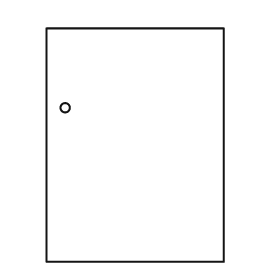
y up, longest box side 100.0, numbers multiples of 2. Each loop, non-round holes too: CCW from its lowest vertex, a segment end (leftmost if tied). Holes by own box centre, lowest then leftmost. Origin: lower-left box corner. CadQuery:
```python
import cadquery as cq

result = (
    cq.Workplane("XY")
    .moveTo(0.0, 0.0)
    .lineTo(76.0, 0.0)
    .lineTo(76.0, 100.0)
    .lineTo(0.0, 100.0)
    .close()
    .moveTo(8.0, 66.0)
    .circle(2.0)
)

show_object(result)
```